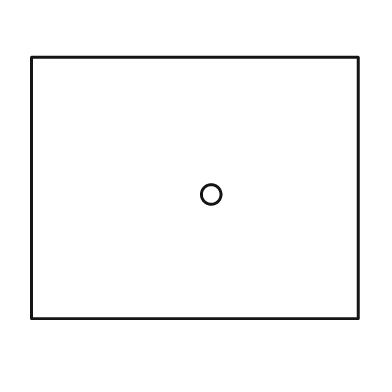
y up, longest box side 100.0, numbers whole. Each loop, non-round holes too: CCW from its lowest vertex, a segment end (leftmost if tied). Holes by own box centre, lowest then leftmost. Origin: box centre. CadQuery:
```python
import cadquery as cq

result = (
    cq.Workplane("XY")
    .moveTo(-50.0, -40.0)
    .lineTo(50.0, -40.0)
    .lineTo(50.0, 40.0)
    .lineTo(-50.0, 40.0)
    .close()
    .moveTo(5.0, -2.0)
    .circle(3.0)
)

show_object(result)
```